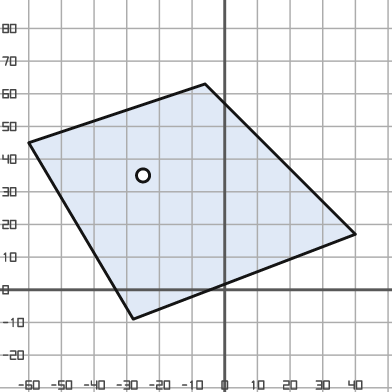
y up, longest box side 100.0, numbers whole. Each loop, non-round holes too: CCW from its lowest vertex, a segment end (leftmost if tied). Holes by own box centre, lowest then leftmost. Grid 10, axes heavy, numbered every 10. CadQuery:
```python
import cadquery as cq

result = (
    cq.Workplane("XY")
    .moveTo(-28.0, -9.0)
    .lineTo(40.0, 17.0)
    .lineTo(-6.0, 63.0)
    .lineTo(-60.0, 45.0)
    .close()
    .moveTo(-25.0, 35.0)
    .circle(2.0)
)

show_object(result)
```